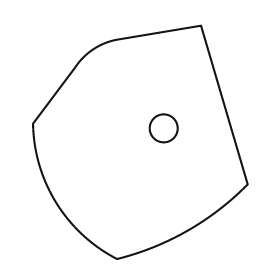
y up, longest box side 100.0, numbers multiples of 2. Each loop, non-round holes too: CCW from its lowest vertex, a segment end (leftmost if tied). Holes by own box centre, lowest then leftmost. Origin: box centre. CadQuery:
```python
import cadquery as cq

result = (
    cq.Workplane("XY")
    .moveTo(-10.0, -50.0)
    .threePointArc((20.0, -38.0), (46.0, -18.0))
    .lineTo(26.0, 50.0)
    .lineTo(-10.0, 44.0)
    .threePointArc((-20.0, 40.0), (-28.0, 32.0))
    .lineTo(-46.0, 8.0)
    .threePointArc((-36.0, -26.0), (-10.0, -50.0))
    .close()
    .moveTo(10.0, 6.0)
    .circle(6.0)
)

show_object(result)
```